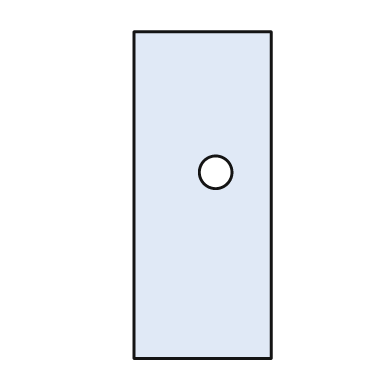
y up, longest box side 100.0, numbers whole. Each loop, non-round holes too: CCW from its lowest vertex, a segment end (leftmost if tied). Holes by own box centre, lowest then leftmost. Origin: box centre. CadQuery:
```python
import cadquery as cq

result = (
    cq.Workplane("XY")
    .moveTo(-21.0, -50.0)
    .lineTo(21.0, -50.0)
    .lineTo(21.0, 50.0)
    .lineTo(-21.0, 50.0)
    .close()
    .moveTo(4.0, 7.0)
    .circle(5.0)
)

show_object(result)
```